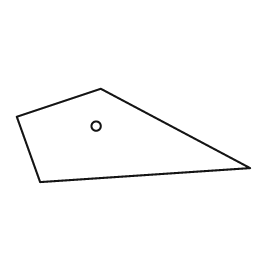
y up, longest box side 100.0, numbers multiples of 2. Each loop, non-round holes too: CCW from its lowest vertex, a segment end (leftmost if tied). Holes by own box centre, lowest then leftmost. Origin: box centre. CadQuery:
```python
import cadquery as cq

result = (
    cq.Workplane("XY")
    .moveTo(-40.0, -20.0)
    .lineTo(50.0, -14.0)
    .lineTo(-14.0, 20.0)
    .lineTo(-50.0, 8.0)
    .close()
    .moveTo(-16.0, 4.0)
    .circle(2.0)
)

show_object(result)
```